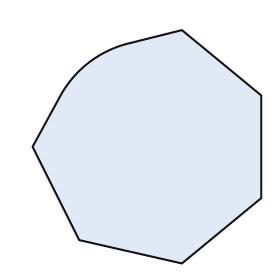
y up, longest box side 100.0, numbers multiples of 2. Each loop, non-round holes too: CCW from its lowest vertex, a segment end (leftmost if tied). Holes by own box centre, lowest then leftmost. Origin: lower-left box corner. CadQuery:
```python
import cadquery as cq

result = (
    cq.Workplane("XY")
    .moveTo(64.0, 0.0)
    .lineTo(98.0, 28.0)
    .lineTo(98.0, 72.0)
    .lineTo(64.0, 100.0)
    .lineTo(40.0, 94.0)
    .threePointArc((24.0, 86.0), (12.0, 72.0))
    .lineTo(0.0, 50.0)
    .lineTo(20.0, 10.0)
    .close()
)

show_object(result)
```